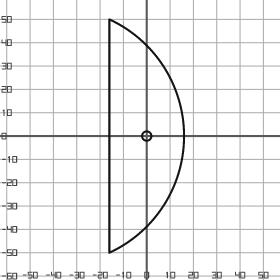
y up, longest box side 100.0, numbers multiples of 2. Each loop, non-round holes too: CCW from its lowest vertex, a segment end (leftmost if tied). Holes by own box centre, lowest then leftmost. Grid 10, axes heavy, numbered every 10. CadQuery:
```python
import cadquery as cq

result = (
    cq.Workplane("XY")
    .moveTo(-16.0, -50.0)
    .threePointArc((16.0, 0.0), (-16.0, 50.0))
    .close()
    .moveTo(0.0, 0.0)
    .circle(2.0)
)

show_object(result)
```